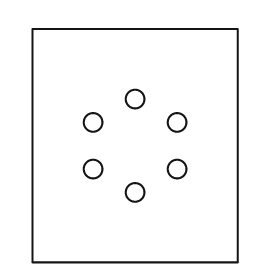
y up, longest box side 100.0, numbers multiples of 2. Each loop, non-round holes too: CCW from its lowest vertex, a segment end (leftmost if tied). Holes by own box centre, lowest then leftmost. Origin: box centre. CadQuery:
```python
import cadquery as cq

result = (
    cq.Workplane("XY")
    .moveTo(-44.0, -50.0)
    .lineTo(44.0, -50.0)
    .lineTo(44.0, 50.0)
    .lineTo(-44.0, 50.0)
    .close()
    .moveTo(0.0, -20.0)
    .circle(4.0)
    .moveTo(-18.0, -10.0)
    .circle(4.0)
    .moveTo(18.0, -10.0)
    .circle(4.0)
    .moveTo(-18.0, 10.0)
    .circle(4.0)
    .moveTo(18.0, 10.0)
    .circle(4.0)
    .moveTo(0.0, 20.0)
    .circle(4.0)
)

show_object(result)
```